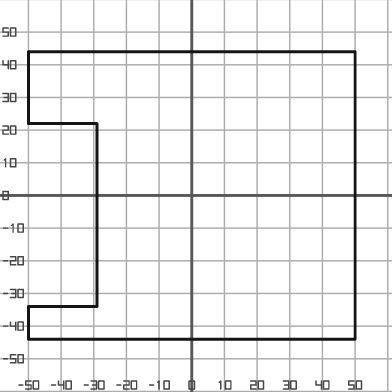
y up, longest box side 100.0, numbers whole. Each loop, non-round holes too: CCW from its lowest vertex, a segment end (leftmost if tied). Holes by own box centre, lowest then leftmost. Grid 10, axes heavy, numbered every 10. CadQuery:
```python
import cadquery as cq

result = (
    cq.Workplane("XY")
    .moveTo(-50.0, -44.0)
    .lineTo(50.0, -44.0)
    .lineTo(50.0, 44.0)
    .lineTo(-50.0, 44.0)
    .lineTo(-50.0, 22.0)
    .lineTo(-29.0, 22.0)
    .lineTo(-29.0, -34.0)
    .lineTo(-50.0, -34.0)
    .close()
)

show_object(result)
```